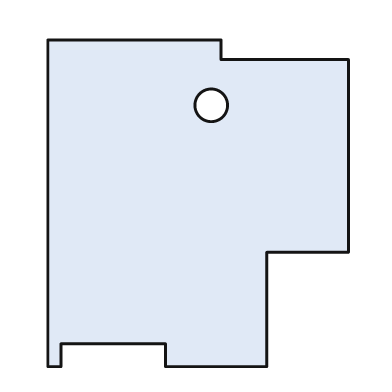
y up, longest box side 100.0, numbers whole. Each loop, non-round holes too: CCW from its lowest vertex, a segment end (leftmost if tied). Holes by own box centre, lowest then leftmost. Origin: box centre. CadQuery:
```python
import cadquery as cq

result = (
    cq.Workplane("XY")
    .moveTo(-46.0, -50.0)
    .lineTo(-42.0, -50.0)
    .lineTo(-42.0, -43.0)
    .lineTo(-10.0, -43.0)
    .lineTo(-10.0, -50.0)
    .lineTo(21.0, -50.0)
    .lineTo(21.0, -15.0)
    .lineTo(46.0, -15.0)
    .lineTo(46.0, 44.0)
    .lineTo(7.0, 44.0)
    .lineTo(7.0, 50.0)
    .lineTo(-46.0, 50.0)
    .close()
    .moveTo(4.0, 30.0)
    .circle(5.0)
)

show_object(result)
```